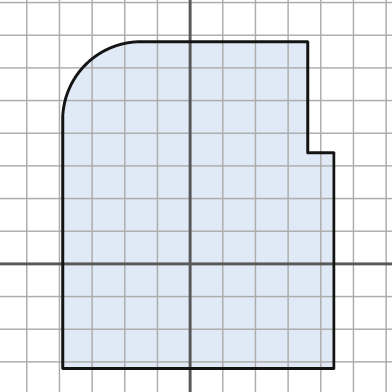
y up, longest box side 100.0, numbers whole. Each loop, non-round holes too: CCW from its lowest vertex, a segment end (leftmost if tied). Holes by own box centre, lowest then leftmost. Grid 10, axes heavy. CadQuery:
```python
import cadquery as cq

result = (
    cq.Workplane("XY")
    .moveTo(-39.0, -32.0)
    .lineTo(44.0, -32.0)
    .lineTo(44.0, 34.0)
    .lineTo(36.0, 34.0)
    .lineTo(36.0, 68.0)
    .lineTo(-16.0, 68.0)
    .threePointArc((-32.0, 61.0), (-39.0, 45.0))
    .close()
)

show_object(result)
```